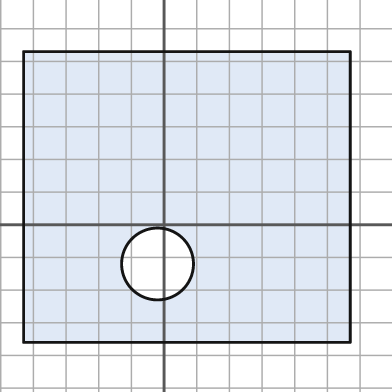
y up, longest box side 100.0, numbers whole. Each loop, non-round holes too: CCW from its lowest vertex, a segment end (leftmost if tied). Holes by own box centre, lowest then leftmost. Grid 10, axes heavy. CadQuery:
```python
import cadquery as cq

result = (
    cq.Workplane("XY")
    .moveTo(-43.0, -36.0)
    .lineTo(57.0, -36.0)
    .lineTo(57.0, 53.0)
    .lineTo(-43.0, 53.0)
    .close()
    .moveTo(-2.0, -12.0)
    .circle(11.0)
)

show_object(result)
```